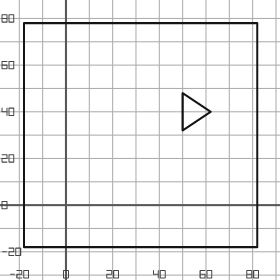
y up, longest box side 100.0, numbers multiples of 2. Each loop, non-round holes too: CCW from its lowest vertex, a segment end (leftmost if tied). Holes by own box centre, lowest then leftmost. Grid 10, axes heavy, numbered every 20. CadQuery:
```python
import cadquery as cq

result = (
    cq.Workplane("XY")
    .moveTo(-18.0, -18.0)
    .lineTo(82.0, -18.0)
    .lineTo(82.0, 78.0)
    .lineTo(-18.0, 78.0)
    .close()
    .moveTo(50.0, 32.0)
    .lineTo(62.0, 40.0)
    .lineTo(50.0, 48.0)
    .close()
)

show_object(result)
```